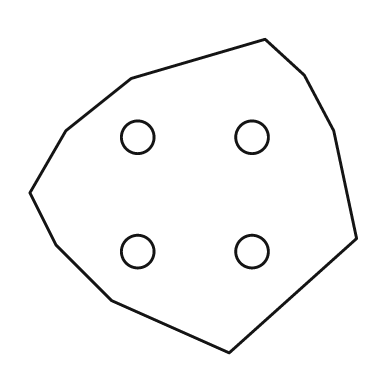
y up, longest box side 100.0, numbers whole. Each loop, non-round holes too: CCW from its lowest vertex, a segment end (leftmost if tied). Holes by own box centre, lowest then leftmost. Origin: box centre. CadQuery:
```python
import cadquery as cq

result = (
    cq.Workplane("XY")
    .moveTo(11.0, -48.0)
    .lineTo(50.0, -13.0)
    .lineTo(43.0, 20.0)
    .lineTo(34.0, 37.0)
    .lineTo(22.0, 48.0)
    .lineTo(-19.0, 36.0)
    .lineTo(-39.0, 20.0)
    .lineTo(-50.0, 1.0)
    .lineTo(-42.0, -15.0)
    .lineTo(-25.0, -32.0)
    .close()
    .moveTo(-17.0, -17.0)
    .circle(5.0)
    .moveTo(18.0, -17.0)
    .circle(5.0)
    .moveTo(-17.0, 18.0)
    .circle(5.0)
    .moveTo(18.0, 18.0)
    .circle(5.0)
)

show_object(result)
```